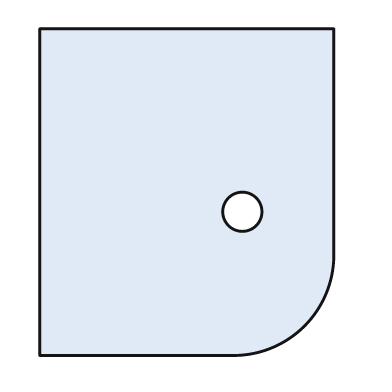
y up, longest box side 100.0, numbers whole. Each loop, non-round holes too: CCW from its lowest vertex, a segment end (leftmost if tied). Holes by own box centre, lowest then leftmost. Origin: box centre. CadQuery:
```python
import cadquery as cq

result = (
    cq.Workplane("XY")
    .moveTo(-45.0, -50.0)
    .lineTo(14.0, -50.0)
    .threePointArc((36.0, -41.0), (45.0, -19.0))
    .lineTo(45.0, 50.0)
    .lineTo(-45.0, 50.0)
    .close()
    .moveTo(17.0, -6.0)
    .circle(6.0)
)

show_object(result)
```